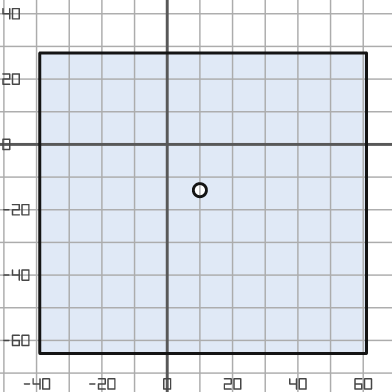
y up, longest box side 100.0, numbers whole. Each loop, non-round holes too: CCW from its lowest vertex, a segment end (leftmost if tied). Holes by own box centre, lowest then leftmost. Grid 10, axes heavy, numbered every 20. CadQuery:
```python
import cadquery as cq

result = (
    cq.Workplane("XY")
    .moveTo(-39.0, -64.0)
    .lineTo(61.0, -64.0)
    .lineTo(61.0, 28.0)
    .lineTo(-39.0, 28.0)
    .close()
    .moveTo(10.0, -14.0)
    .circle(2.0)
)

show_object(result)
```